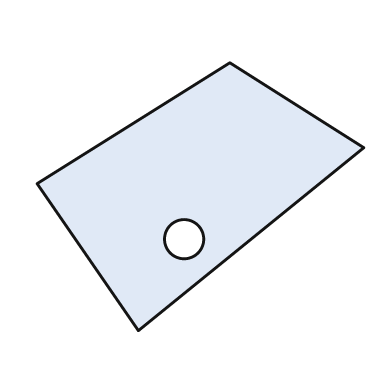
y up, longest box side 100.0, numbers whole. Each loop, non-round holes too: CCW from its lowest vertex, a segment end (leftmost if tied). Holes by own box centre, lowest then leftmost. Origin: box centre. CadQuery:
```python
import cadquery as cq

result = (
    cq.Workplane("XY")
    .moveTo(-19.0, -41.0)
    .lineTo(50.0, 15.0)
    .lineTo(9.0, 41.0)
    .lineTo(-50.0, 4.0)
    .close()
    .moveTo(-5.0, -13.0)
    .circle(6.0)
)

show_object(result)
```